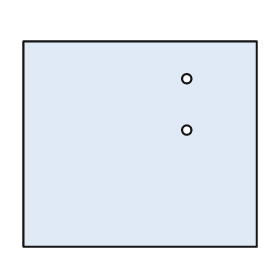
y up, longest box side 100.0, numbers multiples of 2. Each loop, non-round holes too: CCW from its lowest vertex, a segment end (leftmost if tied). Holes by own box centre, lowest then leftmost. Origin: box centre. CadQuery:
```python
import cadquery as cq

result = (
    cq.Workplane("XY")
    .moveTo(-50.0, -44.0)
    .lineTo(50.0, -44.0)
    .lineTo(50.0, 44.0)
    .lineTo(-50.0, 44.0)
    .close()
    .moveTo(20.0, 6.0)
    .circle(2.0)
    .moveTo(20.0, 28.0)
    .circle(2.0)
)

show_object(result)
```